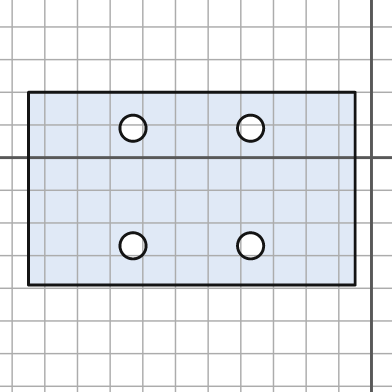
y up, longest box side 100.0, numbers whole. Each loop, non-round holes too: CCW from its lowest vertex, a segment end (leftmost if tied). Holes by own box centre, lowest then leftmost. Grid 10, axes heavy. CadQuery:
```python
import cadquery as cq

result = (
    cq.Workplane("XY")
    .moveTo(-105.0, -39.0)
    .lineTo(-5.0, -39.0)
    .lineTo(-5.0, 20.0)
    .lineTo(-105.0, 20.0)
    .close()
    .moveTo(-73.0, -27.0)
    .circle(4.0)
    .moveTo(-37.0, -27.0)
    .circle(4.0)
    .moveTo(-73.0, 9.0)
    .circle(4.0)
    .moveTo(-37.0, 9.0)
    .circle(4.0)
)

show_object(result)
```